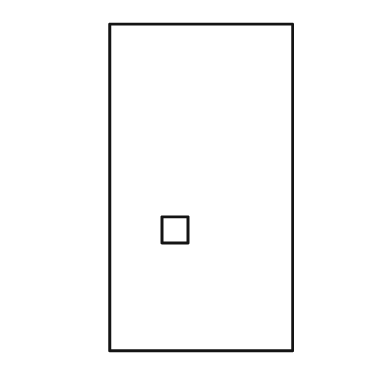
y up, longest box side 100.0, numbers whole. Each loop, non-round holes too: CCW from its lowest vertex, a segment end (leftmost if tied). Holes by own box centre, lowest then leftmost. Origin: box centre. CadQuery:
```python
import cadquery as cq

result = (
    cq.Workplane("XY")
    .moveTo(-28.0, -50.0)
    .lineTo(28.0, -50.0)
    .lineTo(28.0, 50.0)
    .lineTo(-28.0, 50.0)
    .close()
    .moveTo(-12.0, -17.0)
    .lineTo(-4.0, -17.0)
    .lineTo(-4.0, -9.0)
    .lineTo(-12.0, -9.0)
    .close()
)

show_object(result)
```